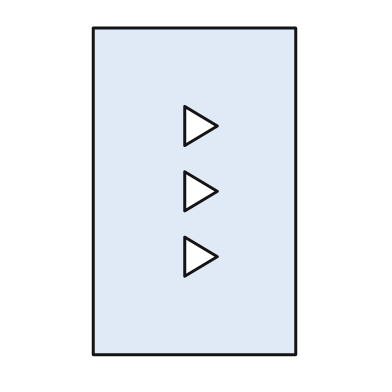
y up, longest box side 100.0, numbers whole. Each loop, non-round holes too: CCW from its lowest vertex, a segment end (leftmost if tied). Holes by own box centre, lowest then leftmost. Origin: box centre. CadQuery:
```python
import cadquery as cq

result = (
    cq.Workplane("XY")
    .moveTo(-31.0, -50.0)
    .lineTo(31.0, -50.0)
    .lineTo(31.0, 50.0)
    .lineTo(-31.0, 50.0)
    .close()
    .moveTo(-3.0, -26.0)
    .lineTo(7.0, -20.0)
    .lineTo(-3.0, -14.0)
    .close()
    .moveTo(-3.0, -6.0)
    .lineTo(7.0, 0.0)
    .lineTo(-3.0, 6.0)
    .close()
    .moveTo(-3.0, 14.0)
    .lineTo(7.0, 20.0)
    .lineTo(-3.0, 26.0)
    .close()
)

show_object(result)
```